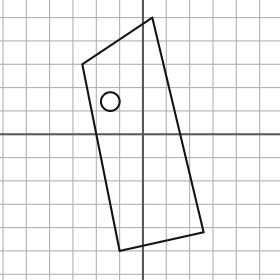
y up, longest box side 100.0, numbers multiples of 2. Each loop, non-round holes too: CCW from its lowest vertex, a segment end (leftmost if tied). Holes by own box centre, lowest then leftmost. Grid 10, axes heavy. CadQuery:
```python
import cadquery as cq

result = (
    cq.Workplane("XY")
    .moveTo(-10.0, -50.0)
    .lineTo(26.0, -42.0)
    .lineTo(4.0, 50.0)
    .lineTo(-26.0, 30.0)
    .close()
    .moveTo(-14.0, 14.0)
    .circle(4.0)
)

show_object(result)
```